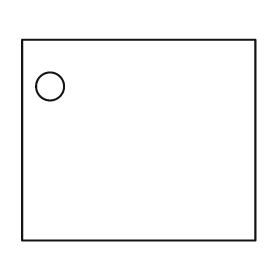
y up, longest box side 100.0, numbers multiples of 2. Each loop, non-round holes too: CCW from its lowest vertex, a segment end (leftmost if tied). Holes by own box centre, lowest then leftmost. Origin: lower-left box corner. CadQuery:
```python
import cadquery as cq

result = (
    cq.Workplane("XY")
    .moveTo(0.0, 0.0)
    .lineTo(100.0, 0.0)
    .lineTo(100.0, 86.0)
    .lineTo(0.0, 86.0)
    .close()
    .moveTo(12.0, 66.0)
    .circle(6.0)
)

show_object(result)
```